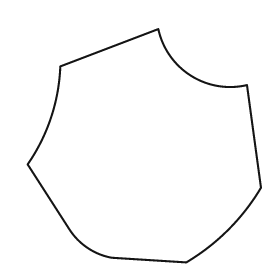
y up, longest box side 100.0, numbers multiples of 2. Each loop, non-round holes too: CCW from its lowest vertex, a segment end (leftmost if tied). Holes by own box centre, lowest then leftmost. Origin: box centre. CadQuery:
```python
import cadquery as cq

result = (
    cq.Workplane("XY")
    .moveTo(18.0, -50.0)
    .threePointArc((36.0, -36.0), (50.0, -18.0))
    .lineTo(44.0, 26.0)
    .threePointArc((20.0, 30.0), (6.0, 50.0))
    .lineTo(-36.0, 34.0)
    .threePointArc((-40.0, 12.0), (-50.0, -8.0))
    .lineTo(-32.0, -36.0)
    .threePointArc((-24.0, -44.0), (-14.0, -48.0))
    .close()
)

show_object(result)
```